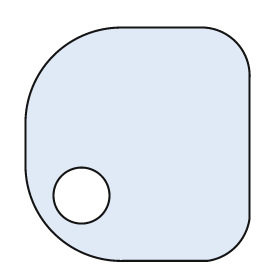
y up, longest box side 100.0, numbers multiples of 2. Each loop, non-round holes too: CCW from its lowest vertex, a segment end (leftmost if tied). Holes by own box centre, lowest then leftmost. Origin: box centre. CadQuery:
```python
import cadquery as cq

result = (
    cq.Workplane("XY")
    .moveTo(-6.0, -50.0)
    .lineTo(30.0, -50.0)
    .threePointArc((42.0, -44.0), (48.0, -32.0))
    .lineTo(48.0, 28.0)
    .threePointArc((42.0, 44.0), (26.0, 50.0))
    .lineTo(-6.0, 50.0)
    .threePointArc((-36.0, 38.0), (-48.0, 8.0))
    .lineTo(-48.0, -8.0)
    .threePointArc((-36.0, -38.0), (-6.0, -50.0))
    .close()
    .moveTo(-24.0, -22.0)
    .circle(12.0)
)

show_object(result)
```